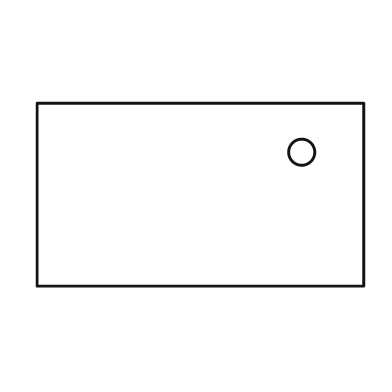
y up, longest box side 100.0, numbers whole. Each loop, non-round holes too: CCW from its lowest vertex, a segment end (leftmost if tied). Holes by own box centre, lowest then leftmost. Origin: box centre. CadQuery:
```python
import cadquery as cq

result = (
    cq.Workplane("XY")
    .moveTo(-50.0, -28.0)
    .lineTo(50.0, -28.0)
    .lineTo(50.0, 28.0)
    .lineTo(-50.0, 28.0)
    .close()
    .moveTo(31.0, 13.0)
    .circle(4.0)
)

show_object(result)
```